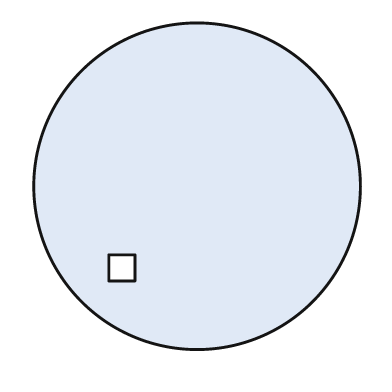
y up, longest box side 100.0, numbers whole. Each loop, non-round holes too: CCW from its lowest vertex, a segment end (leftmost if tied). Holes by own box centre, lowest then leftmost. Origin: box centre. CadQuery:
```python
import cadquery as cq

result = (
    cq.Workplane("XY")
    .moveTo(0.0, 0.0)
    .circle(50.0)
    .moveTo(-27.0, -29.0)
    .lineTo(-19.0, -29.0)
    .lineTo(-19.0, -21.0)
    .lineTo(-27.0, -21.0)
    .close()
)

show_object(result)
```